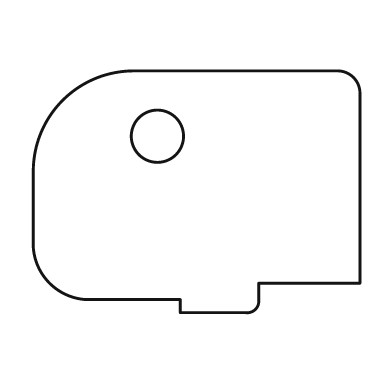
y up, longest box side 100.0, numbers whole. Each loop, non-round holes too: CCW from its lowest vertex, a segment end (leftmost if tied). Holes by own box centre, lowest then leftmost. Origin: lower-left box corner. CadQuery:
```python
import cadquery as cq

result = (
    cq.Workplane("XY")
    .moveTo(45.0, 0.0)
    .lineTo(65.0, 0.0)
    .threePointArc((68.0, 1.0), (69.0, 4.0))
    .lineTo(69.0, 9.0)
    .lineTo(100.0, 9.0)
    .lineTo(100.0, 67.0)
    .threePointArc((98.0, 72.0), (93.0, 74.0))
    .lineTo(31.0, 74.0)
    .threePointArc((9.0, 65.0), (0.0, 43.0))
    .lineTo(0.0, 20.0)
    .threePointArc((5.0, 9.0), (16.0, 4.0))
    .lineTo(45.0, 4.0)
    .close()
    .moveTo(38.0, 54.0)
    .circle(8.0)
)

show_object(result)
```